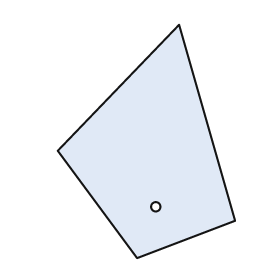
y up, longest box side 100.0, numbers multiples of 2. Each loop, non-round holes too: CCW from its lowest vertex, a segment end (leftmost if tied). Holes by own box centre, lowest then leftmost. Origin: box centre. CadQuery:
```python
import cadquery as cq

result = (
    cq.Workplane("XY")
    .moveTo(-4.0, -50.0)
    .lineTo(38.0, -34.0)
    .lineTo(14.0, 50.0)
    .lineTo(-38.0, -4.0)
    .close()
    .moveTo(4.0, -28.0)
    .circle(2.0)
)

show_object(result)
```